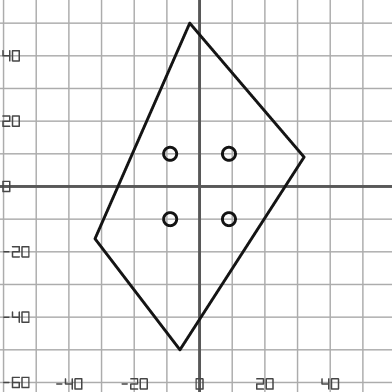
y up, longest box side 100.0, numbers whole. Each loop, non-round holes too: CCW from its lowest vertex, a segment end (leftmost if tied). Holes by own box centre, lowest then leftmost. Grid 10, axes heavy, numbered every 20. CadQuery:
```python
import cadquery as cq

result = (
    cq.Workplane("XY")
    .moveTo(-6.0, -50.0)
    .lineTo(32.0, 9.0)
    .lineTo(-3.0, 50.0)
    .lineTo(-32.0, -16.0)
    .close()
    .moveTo(-9.0, -10.0)
    .circle(2.0)
    .moveTo(9.0, -10.0)
    .circle(2.0)
    .moveTo(-9.0, 10.0)
    .circle(2.0)
    .moveTo(9.0, 10.0)
    .circle(2.0)
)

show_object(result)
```